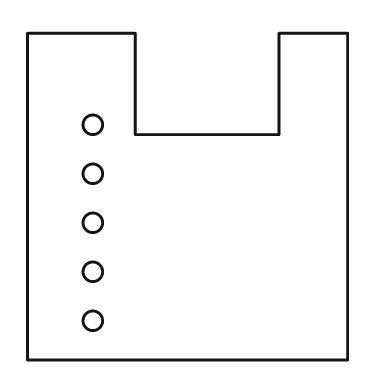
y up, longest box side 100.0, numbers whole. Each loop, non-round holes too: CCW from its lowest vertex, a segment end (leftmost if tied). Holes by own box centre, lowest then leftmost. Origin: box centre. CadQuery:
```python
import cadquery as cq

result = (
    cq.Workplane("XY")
    .moveTo(-49.0, -50.0)
    .lineTo(49.0, -50.0)
    .lineTo(49.0, 50.0)
    .lineTo(28.0, 50.0)
    .lineTo(28.0, 19.0)
    .lineTo(-16.0, 19.0)
    .lineTo(-16.0, 50.0)
    .lineTo(-49.0, 50.0)
    .close()
    .moveTo(-29.0, -38.0)
    .circle(3.0)
    .moveTo(-29.0, -23.0)
    .circle(3.0)
    .moveTo(-29.0, -8.0)
    .circle(3.0)
    .moveTo(-29.0, 7.0)
    .circle(3.0)
    .moveTo(-29.0, 22.0)
    .circle(3.0)
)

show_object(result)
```